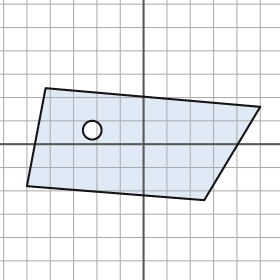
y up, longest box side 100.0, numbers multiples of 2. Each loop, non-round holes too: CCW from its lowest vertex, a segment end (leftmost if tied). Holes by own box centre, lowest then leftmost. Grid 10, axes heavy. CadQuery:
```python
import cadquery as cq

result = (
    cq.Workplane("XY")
    .moveTo(26.0, -24.0)
    .lineTo(50.0, 16.0)
    .lineTo(-42.0, 24.0)
    .lineTo(-50.0, -18.0)
    .close()
    .moveTo(-22.0, 6.0)
    .circle(4.0)
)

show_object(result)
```